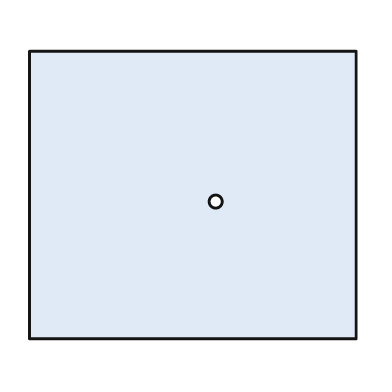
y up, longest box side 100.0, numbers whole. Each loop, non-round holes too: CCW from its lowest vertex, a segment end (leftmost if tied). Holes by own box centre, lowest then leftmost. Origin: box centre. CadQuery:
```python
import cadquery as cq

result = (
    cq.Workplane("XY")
    .moveTo(-50.0, -44.0)
    .lineTo(50.0, -44.0)
    .lineTo(50.0, 44.0)
    .lineTo(-50.0, 44.0)
    .close()
    .moveTo(7.0, -2.0)
    .circle(2.0)
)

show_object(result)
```